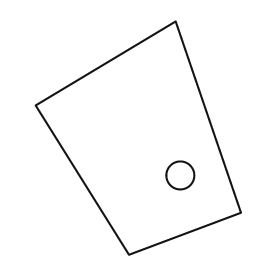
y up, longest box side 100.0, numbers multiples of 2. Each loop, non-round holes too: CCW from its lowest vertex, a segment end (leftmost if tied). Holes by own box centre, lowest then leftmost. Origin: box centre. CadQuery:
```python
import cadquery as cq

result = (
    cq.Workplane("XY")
    .moveTo(-4.0, -50.0)
    .lineTo(44.0, -32.0)
    .lineTo(16.0, 50.0)
    .lineTo(-44.0, 14.0)
    .close()
    .moveTo(18.0, -16.0)
    .circle(6.0)
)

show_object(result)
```